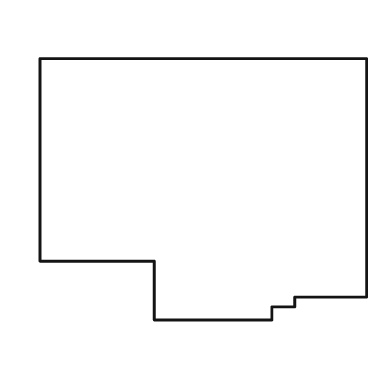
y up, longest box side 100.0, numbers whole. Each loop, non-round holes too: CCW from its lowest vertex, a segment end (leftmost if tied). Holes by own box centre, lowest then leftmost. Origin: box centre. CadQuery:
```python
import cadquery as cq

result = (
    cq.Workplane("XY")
    .moveTo(-15.0, -40.0)
    .lineTo(21.0, -40.0)
    .lineTo(21.0, -36.0)
    .lineTo(28.0, -36.0)
    .lineTo(28.0, -33.0)
    .lineTo(50.0, -33.0)
    .lineTo(50.0, 40.0)
    .lineTo(-50.0, 40.0)
    .lineTo(-50.0, -22.0)
    .lineTo(-15.0, -22.0)
    .close()
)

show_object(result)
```